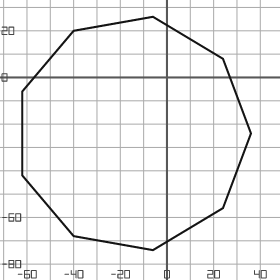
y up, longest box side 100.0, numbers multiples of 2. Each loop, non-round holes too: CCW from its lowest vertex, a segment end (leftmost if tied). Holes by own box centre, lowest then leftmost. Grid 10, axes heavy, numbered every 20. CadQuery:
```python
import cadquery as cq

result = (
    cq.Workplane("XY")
    .moveTo(-6.0, -74.0)
    .lineTo(24.0, -56.0)
    .lineTo(36.0, -24.0)
    .lineTo(24.0, 8.0)
    .lineTo(-6.0, 26.0)
    .lineTo(-40.0, 20.0)
    .lineTo(-62.0, -6.0)
    .lineTo(-62.0, -42.0)
    .lineTo(-40.0, -68.0)
    .close()
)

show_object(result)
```